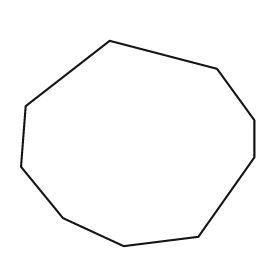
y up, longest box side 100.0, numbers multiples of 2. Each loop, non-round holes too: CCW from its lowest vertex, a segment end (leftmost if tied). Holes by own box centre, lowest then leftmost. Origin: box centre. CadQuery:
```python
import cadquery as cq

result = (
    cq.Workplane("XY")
    .moveTo(-6.0, -44.0)
    .lineTo(26.0, -40.0)
    .lineTo(50.0, -6.0)
    .lineTo(50.0, 10.0)
    .lineTo(34.0, 32.0)
    .lineTo(-12.0, 44.0)
    .lineTo(-48.0, 16.0)
    .lineTo(-50.0, -10.0)
    .lineTo(-32.0, -32.0)
    .close()
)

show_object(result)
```